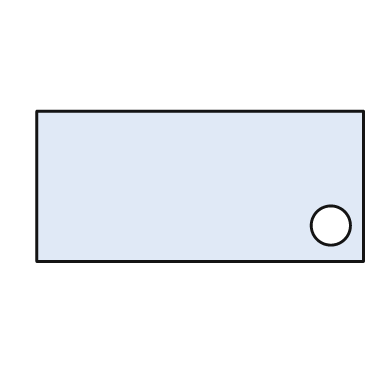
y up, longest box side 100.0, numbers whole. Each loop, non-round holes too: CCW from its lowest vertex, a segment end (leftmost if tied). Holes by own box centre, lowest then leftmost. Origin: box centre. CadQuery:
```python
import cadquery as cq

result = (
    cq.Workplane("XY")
    .moveTo(-50.0, -23.0)
    .lineTo(50.0, -23.0)
    .lineTo(50.0, 23.0)
    .lineTo(-50.0, 23.0)
    .close()
    .moveTo(40.0, -12.0)
    .circle(6.0)
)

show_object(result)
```